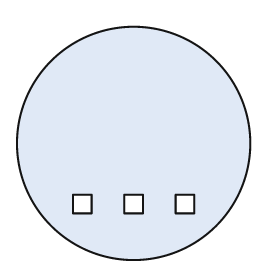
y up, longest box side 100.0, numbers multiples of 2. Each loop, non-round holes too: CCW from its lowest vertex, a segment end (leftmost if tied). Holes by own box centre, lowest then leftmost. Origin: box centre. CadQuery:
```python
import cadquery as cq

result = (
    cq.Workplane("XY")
    .moveTo(0.0, 0.0)
    .circle(50.0)
    .moveTo(-26.0, -30.0)
    .lineTo(-18.0, -30.0)
    .lineTo(-18.0, -22.0)
    .lineTo(-26.0, -22.0)
    .close()
    .moveTo(-4.0, -30.0)
    .lineTo(4.0, -30.0)
    .lineTo(4.0, -22.0)
    .lineTo(-4.0, -22.0)
    .close()
    .moveTo(18.0, -30.0)
    .lineTo(26.0, -30.0)
    .lineTo(26.0, -22.0)
    .lineTo(18.0, -22.0)
    .close()
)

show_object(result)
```